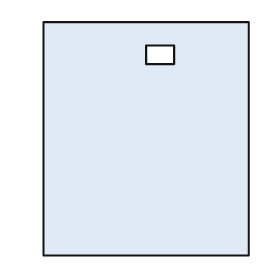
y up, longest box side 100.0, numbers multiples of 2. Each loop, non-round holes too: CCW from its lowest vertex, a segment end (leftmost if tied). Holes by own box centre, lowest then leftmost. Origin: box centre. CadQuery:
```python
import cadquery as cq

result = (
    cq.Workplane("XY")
    .moveTo(-44.0, -50.0)
    .lineTo(44.0, -50.0)
    .lineTo(44.0, 50.0)
    .lineTo(-44.0, 50.0)
    .close()
    .moveTo(0.0, 32.0)
    .lineTo(12.0, 32.0)
    .lineTo(12.0, 40.0)
    .lineTo(0.0, 40.0)
    .close()
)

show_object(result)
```